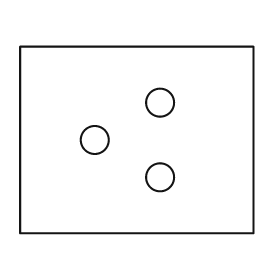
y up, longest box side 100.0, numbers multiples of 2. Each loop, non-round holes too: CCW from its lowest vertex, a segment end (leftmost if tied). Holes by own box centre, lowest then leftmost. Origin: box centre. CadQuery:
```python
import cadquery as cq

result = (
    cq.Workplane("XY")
    .moveTo(-50.0, -40.0)
    .lineTo(50.0, -40.0)
    .lineTo(50.0, 40.0)
    .lineTo(-50.0, 40.0)
    .close()
    .moveTo(10.0, -16.0)
    .circle(6.0)
    .moveTo(-18.0, 0.0)
    .circle(6.0)
    .moveTo(10.0, 16.0)
    .circle(6.0)
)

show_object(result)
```